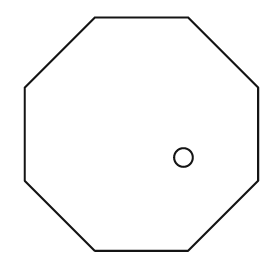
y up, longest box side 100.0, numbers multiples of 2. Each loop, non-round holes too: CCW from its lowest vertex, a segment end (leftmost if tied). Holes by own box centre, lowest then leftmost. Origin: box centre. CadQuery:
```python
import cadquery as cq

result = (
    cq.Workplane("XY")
    .moveTo(-20.0, -50.0)
    .lineTo(20.0, -50.0)
    .lineTo(50.0, -20.0)
    .lineTo(50.0, 20.0)
    .lineTo(20.0, 50.0)
    .lineTo(-20.0, 50.0)
    .lineTo(-50.0, 20.0)
    .lineTo(-50.0, -20.0)
    .close()
    .moveTo(18.0, -10.0)
    .circle(4.0)
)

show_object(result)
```